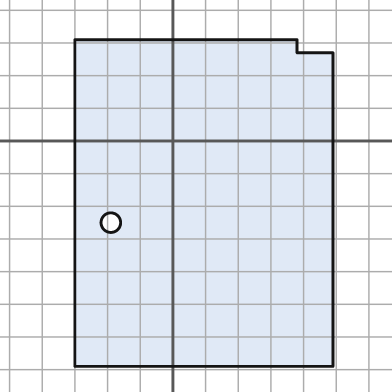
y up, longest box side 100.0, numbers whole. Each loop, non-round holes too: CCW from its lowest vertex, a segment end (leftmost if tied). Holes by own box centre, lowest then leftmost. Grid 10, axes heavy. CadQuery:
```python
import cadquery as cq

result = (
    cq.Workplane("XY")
    .moveTo(-30.0, -69.0)
    .lineTo(49.0, -69.0)
    .lineTo(49.0, 27.0)
    .lineTo(38.0, 27.0)
    .lineTo(38.0, 31.0)
    .lineTo(-30.0, 31.0)
    .close()
    .moveTo(-19.0, -25.0)
    .circle(3.0)
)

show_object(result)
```